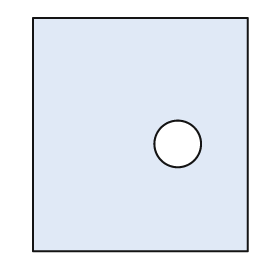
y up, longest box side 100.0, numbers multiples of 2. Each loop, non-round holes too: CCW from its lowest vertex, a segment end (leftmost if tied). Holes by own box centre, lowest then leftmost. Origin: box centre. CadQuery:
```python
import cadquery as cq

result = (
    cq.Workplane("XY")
    .moveTo(-46.0, -50.0)
    .lineTo(46.0, -50.0)
    .lineTo(46.0, 50.0)
    .lineTo(-46.0, 50.0)
    .close()
    .moveTo(16.0, -4.0)
    .circle(10.0)
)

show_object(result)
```